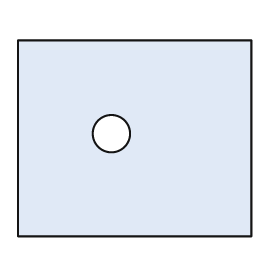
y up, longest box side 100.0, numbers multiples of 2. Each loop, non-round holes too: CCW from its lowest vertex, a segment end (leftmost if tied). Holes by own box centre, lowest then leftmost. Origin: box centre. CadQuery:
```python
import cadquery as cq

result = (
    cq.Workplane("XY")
    .moveTo(-50.0, -42.0)
    .lineTo(50.0, -42.0)
    .lineTo(50.0, 42.0)
    .lineTo(-50.0, 42.0)
    .close()
    .moveTo(-10.0, 2.0)
    .circle(8.0)
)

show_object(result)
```